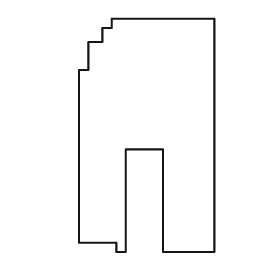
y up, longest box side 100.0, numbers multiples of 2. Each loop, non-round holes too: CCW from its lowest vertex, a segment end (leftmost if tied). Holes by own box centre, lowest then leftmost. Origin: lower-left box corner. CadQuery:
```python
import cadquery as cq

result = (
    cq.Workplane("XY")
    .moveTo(16.0, 0.0)
    .lineTo(20.0, 0.0)
    .lineTo(20.0, 44.0)
    .lineTo(36.0, 44.0)
    .lineTo(36.0, 0.0)
    .lineTo(58.0, 0.0)
    .lineTo(58.0, 100.0)
    .lineTo(14.0, 100.0)
    .lineTo(14.0, 96.0)
    .lineTo(10.0, 96.0)
    .lineTo(10.0, 90.0)
    .lineTo(4.0, 90.0)
    .lineTo(4.0, 78.0)
    .lineTo(0.0, 78.0)
    .lineTo(0.0, 4.0)
    .lineTo(16.0, 4.0)
    .close()
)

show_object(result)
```